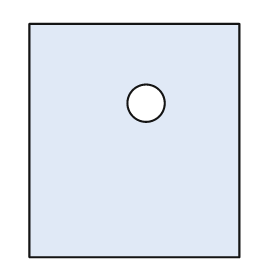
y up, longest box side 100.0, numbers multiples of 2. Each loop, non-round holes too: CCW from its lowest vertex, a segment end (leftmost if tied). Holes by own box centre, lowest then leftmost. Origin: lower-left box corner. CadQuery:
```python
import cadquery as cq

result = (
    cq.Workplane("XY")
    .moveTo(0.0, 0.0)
    .lineTo(90.0, 0.0)
    .lineTo(90.0, 100.0)
    .lineTo(0.0, 100.0)
    .close()
    .moveTo(50.0, 66.0)
    .circle(8.0)
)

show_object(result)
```